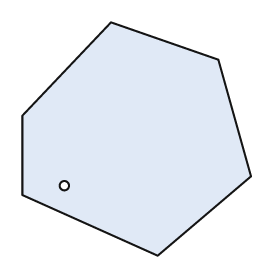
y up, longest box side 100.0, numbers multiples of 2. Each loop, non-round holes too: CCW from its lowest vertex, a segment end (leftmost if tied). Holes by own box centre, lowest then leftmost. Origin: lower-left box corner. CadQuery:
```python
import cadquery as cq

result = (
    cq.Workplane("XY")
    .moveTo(58.0, 0.0)
    .lineTo(98.0, 34.0)
    .lineTo(84.0, 84.0)
    .lineTo(38.0, 100.0)
    .lineTo(0.0, 60.0)
    .lineTo(0.0, 26.0)
    .close()
    .moveTo(18.0, 30.0)
    .circle(2.0)
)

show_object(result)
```